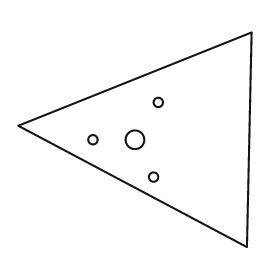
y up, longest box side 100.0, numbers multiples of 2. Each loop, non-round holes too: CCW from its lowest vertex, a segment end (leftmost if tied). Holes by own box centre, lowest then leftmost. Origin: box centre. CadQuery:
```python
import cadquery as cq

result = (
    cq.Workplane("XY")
    .moveTo(48.0, -46.0)
    .lineTo(50.0, 46.0)
    .lineTo(-50.0, 6.0)
    .close()
    .moveTo(8.0, -16.0)
    .circle(2.0)
    .moveTo(-18.0, 0.0)
    .circle(2.0)
    .moveTo(0.0, 0.0)
    .circle(4.0)
    .moveTo(10.0, 16.0)
    .circle(2.0)
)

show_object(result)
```